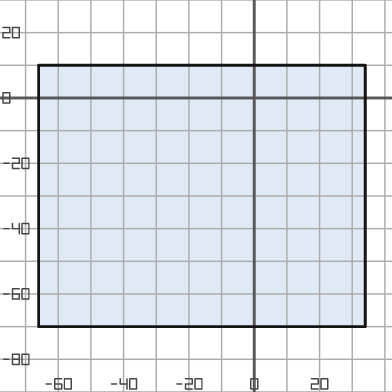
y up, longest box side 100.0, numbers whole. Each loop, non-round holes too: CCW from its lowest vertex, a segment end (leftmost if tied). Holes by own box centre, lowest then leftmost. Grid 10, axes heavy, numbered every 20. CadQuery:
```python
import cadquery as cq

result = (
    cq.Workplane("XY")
    .moveTo(-66.0, -70.0)
    .lineTo(34.0, -70.0)
    .lineTo(34.0, 10.0)
    .lineTo(-66.0, 10.0)
    .close()
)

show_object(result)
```